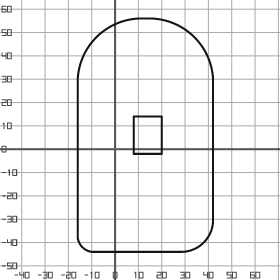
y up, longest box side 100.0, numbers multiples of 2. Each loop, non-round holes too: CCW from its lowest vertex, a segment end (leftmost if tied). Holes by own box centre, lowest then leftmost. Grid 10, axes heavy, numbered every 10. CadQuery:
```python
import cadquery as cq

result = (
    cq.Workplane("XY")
    .moveTo(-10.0, -44.0)
    .lineTo(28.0, -44.0)
    .threePointArc((38.0, -40.0), (42.0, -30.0))
    .lineTo(42.0, 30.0)
    .threePointArc((34.0, 48.0), (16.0, 56.0))
    .lineTo(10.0, 56.0)
    .threePointArc((-8.0, 48.0), (-16.0, 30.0))
    .lineTo(-16.0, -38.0)
    .threePointArc((-14.0, -42.0), (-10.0, -44.0))
    .close()
    .moveTo(8.0, -2.0)
    .lineTo(20.0, -2.0)
    .lineTo(20.0, 14.0)
    .lineTo(8.0, 14.0)
    .close()
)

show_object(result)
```